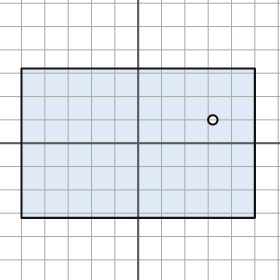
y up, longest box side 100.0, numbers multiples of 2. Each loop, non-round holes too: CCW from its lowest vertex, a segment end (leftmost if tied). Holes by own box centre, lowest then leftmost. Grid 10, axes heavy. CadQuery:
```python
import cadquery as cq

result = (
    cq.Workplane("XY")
    .moveTo(-50.0, -32.0)
    .lineTo(50.0, -32.0)
    .lineTo(50.0, 32.0)
    .lineTo(-50.0, 32.0)
    .close()
    .moveTo(32.0, 10.0)
    .circle(2.0)
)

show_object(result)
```